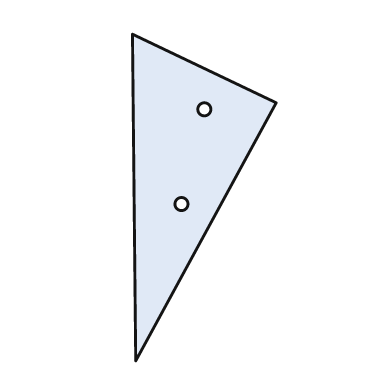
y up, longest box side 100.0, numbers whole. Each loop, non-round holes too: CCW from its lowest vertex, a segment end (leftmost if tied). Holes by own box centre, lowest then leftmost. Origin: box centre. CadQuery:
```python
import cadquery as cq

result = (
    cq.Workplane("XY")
    .moveTo(-21.0, -50.0)
    .lineTo(22.0, 29.0)
    .lineTo(-22.0, 50.0)
    .close()
    .moveTo(-7.0, -2.0)
    .circle(2.0)
    .moveTo(0.0, 27.0)
    .circle(2.0)
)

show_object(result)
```